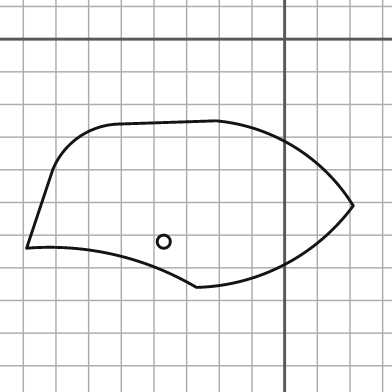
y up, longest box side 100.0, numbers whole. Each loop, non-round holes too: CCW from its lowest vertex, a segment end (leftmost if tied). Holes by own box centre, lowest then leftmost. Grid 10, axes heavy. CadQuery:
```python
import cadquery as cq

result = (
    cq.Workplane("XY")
    .moveTo(-27.0, -76.0)
    .threePointArc((0.0, -69.0), (21.0, -51.0))
    .threePointArc((3.0, -33.0), (-21.0, -25.0))
    .lineTo(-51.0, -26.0)
    .threePointArc((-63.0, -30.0), (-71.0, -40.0))
    .lineTo(-79.0, -64.0)
    .threePointArc((-52.0, -66.0), (-27.0, -76.0))
    .close()
    .moveTo(-37.0, -62.0)
    .circle(2.0)
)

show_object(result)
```